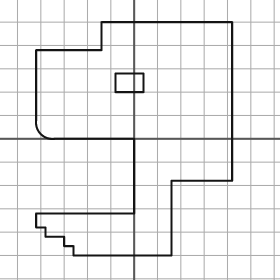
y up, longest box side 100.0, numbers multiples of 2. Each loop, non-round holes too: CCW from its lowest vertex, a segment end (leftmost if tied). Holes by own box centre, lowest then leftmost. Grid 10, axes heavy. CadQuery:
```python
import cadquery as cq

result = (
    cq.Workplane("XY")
    .moveTo(-26.0, -50.0)
    .lineTo(16.0, -50.0)
    .lineTo(16.0, -18.0)
    .lineTo(42.0, -18.0)
    .lineTo(42.0, 50.0)
    .lineTo(-14.0, 50.0)
    .lineTo(-14.0, 38.0)
    .lineTo(-42.0, 38.0)
    .lineTo(-42.0, 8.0)
    .threePointArc((-40.0, 2.0), (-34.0, 0.0))
    .lineTo(0.0, 0.0)
    .lineTo(0.0, -32.0)
    .lineTo(-42.0, -32.0)
    .lineTo(-42.0, -38.0)
    .lineTo(-38.0, -38.0)
    .lineTo(-38.0, -42.0)
    .lineTo(-30.0, -42.0)
    .lineTo(-30.0, -46.0)
    .lineTo(-26.0, -46.0)
    .close()
    .moveTo(-8.0, 20.0)
    .lineTo(4.0, 20.0)
    .lineTo(4.0, 28.0)
    .lineTo(-8.0, 28.0)
    .close()
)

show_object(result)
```